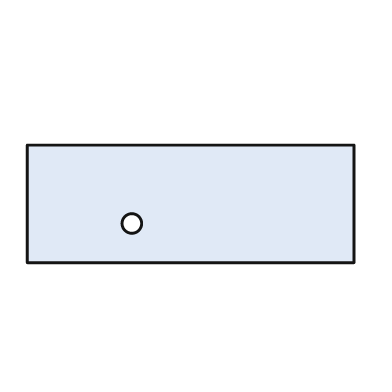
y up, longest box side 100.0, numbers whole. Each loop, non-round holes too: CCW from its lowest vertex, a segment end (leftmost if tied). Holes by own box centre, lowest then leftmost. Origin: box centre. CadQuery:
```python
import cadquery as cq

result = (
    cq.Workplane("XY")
    .moveTo(-50.0, -18.0)
    .lineTo(50.0, -18.0)
    .lineTo(50.0, 18.0)
    .lineTo(-50.0, 18.0)
    .close()
    .moveTo(-18.0, -6.0)
    .circle(3.0)
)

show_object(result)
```